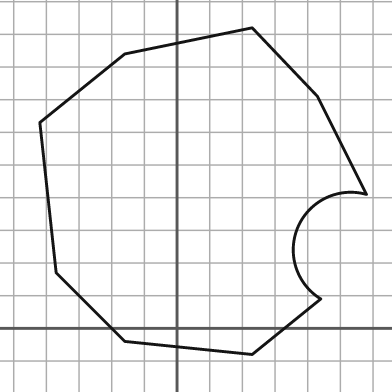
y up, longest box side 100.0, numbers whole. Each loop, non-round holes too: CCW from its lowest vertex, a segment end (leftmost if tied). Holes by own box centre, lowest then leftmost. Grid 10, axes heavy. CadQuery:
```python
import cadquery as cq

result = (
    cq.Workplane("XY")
    .moveTo(23.0, -8.0)
    .lineTo(44.0, 9.0)
    .threePointArc((37.0, 31.0), (58.0, 41.0))
    .lineTo(43.0, 71.0)
    .lineTo(23.0, 92.0)
    .lineTo(-16.0, 84.0)
    .lineTo(-42.0, 63.0)
    .lineTo(-37.0, 17.0)
    .lineTo(-16.0, -4.0)
    .close()
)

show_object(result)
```